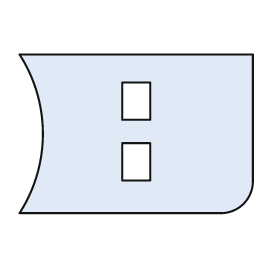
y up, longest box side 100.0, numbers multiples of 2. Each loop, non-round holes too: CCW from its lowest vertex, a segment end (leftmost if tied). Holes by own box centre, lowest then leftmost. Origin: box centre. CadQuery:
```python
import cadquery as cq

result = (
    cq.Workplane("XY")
    .moveTo(-50.0, -34.0)
    .lineTo(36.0, -34.0)
    .threePointArc((46.0, -30.0), (50.0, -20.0))
    .lineTo(50.0, 34.0)
    .lineTo(-50.0, 34.0)
    .threePointArc((-40.0, 0.0), (-50.0, -34.0))
    .close()
    .moveTo(-6.0, -20.0)
    .lineTo(6.0, -20.0)
    .lineTo(6.0, -4.0)
    .lineTo(-6.0, -4.0)
    .close()
    .moveTo(-6.0, 6.0)
    .lineTo(6.0, 6.0)
    .lineTo(6.0, 22.0)
    .lineTo(-6.0, 22.0)
    .close()
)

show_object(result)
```